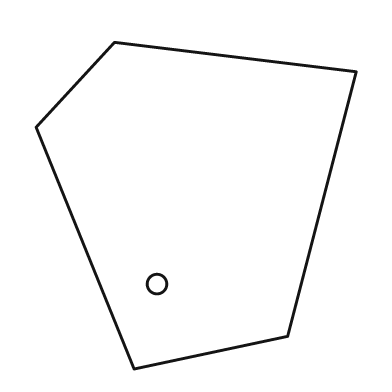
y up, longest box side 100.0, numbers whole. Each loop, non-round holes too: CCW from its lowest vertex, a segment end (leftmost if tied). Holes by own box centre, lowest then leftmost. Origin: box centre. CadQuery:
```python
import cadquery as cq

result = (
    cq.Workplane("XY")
    .moveTo(-19.0, -50.0)
    .lineTo(28.0, -40.0)
    .lineTo(49.0, 41.0)
    .lineTo(-25.0, 50.0)
    .lineTo(-49.0, 24.0)
    .close()
    .moveTo(-12.0, -24.0)
    .circle(3.0)
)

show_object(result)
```